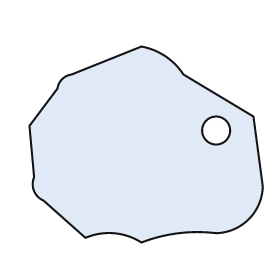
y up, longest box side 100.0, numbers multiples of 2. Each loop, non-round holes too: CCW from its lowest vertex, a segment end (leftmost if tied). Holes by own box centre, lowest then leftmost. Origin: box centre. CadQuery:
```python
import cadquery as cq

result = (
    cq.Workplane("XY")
    .moveTo(-2.0, -42.0)
    .threePointArc((14.0, -38.0), (30.0, -38.0))
    .threePointArc((44.0, -32.0), (50.0, -18.0))
    .lineTo(46.0, 12.0)
    .lineTo(16.0, 30.0)
    .threePointArc((8.0, 38.0), (-2.0, 42.0))
    .lineTo(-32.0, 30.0)
    .threePointArc((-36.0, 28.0), (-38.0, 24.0))
    .lineTo(-50.0, 8.0)
    .lineTo(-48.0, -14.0)
    .threePointArc((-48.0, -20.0), (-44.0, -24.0))
    .lineTo(-26.0, -40.0)
    .threePointArc((-14.0, -38.0), (-2.0, -42.0))
    .close()
    .moveTo(30.0, 6.0)
    .circle(6.0)
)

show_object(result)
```